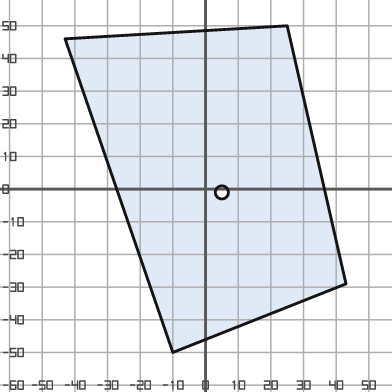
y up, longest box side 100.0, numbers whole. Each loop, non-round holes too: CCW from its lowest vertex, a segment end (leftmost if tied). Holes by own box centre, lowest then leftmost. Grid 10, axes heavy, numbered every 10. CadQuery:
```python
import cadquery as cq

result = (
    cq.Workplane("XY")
    .moveTo(-10.0, -50.0)
    .lineTo(43.0, -29.0)
    .lineTo(25.0, 50.0)
    .lineTo(-43.0, 46.0)
    .close()
    .moveTo(5.0, -1.0)
    .circle(2.0)
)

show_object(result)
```